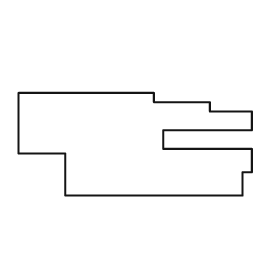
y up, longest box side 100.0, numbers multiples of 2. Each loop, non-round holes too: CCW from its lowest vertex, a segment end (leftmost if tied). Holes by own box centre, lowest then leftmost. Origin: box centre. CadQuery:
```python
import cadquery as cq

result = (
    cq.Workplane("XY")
    .moveTo(-30.0, -22.0)
    .lineTo(46.0, -22.0)
    .lineTo(46.0, -12.0)
    .lineTo(50.0, -12.0)
    .lineTo(50.0, -2.0)
    .lineTo(12.0, -2.0)
    .lineTo(12.0, 6.0)
    .lineTo(50.0, 6.0)
    .lineTo(50.0, 14.0)
    .lineTo(32.0, 14.0)
    .lineTo(32.0, 18.0)
    .lineTo(8.0, 18.0)
    .lineTo(8.0, 22.0)
    .lineTo(-50.0, 22.0)
    .lineTo(-50.0, -4.0)
    .lineTo(-30.0, -4.0)
    .close()
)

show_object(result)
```